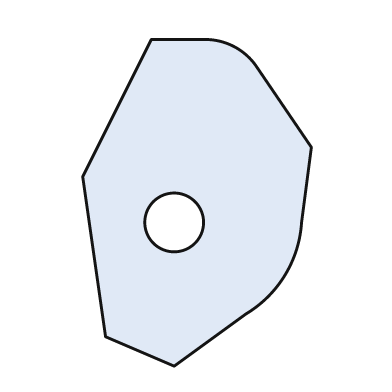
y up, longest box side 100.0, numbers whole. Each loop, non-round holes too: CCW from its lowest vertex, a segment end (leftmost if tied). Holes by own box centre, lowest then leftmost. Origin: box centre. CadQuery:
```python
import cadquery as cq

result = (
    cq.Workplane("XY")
    .moveTo(-7.0, -50.0)
    .lineTo(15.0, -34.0)
    .threePointArc((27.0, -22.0), (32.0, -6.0))
    .lineTo(35.0, 17.0)
    .lineTo(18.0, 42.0)
    .threePointArc((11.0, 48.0), (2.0, 50.0))
    .lineTo(-14.0, 50.0)
    .lineTo(-35.0, 8.0)
    .lineTo(-28.0, -41.0)
    .close()
    .moveTo(-7.0, -6.0)
    .circle(9.0)
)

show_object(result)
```